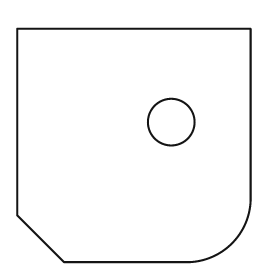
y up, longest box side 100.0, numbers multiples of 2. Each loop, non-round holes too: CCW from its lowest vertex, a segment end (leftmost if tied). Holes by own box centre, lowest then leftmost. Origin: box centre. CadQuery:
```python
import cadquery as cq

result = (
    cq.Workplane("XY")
    .moveTo(-30.0, -50.0)
    .lineTo(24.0, -50.0)
    .threePointArc((42.0, -42.0), (50.0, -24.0))
    .lineTo(50.0, 50.0)
    .lineTo(-50.0, 50.0)
    .lineTo(-50.0, -30.0)
    .close()
    .moveTo(16.0, 10.0)
    .circle(10.0)
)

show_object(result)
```